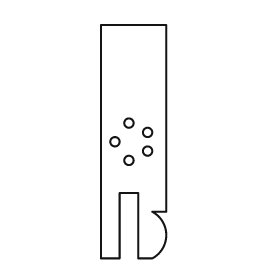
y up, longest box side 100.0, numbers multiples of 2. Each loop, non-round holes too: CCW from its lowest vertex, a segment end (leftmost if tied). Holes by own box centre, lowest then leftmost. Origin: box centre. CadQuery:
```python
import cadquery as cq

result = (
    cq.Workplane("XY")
    .moveTo(-14.0, -50.0)
    .lineTo(-6.0, -50.0)
    .lineTo(-6.0, -22.0)
    .lineTo(2.0, -22.0)
    .lineTo(2.0, -50.0)
    .lineTo(8.0, -50.0)
    .threePointArc((14.0, -40.0), (8.0, -30.0))
    .lineTo(14.0, -30.0)
    .lineTo(14.0, 50.0)
    .lineTo(-14.0, 50.0)
    .close()
    .moveTo(-2.0, -8.0)
    .circle(2.0)
    .moveTo(6.0, -4.0)
    .circle(2.0)
    .moveTo(-8.0, 0.0)
    .circle(2.0)
    .moveTo(6.0, 4.0)
    .circle(2.0)
    .moveTo(-2.0, 8.0)
    .circle(2.0)
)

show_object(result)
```